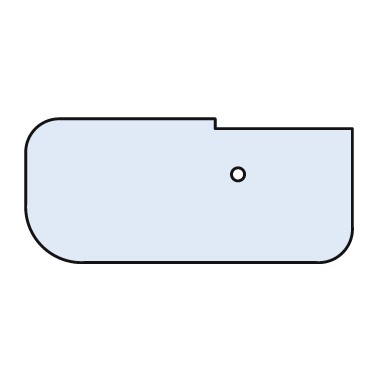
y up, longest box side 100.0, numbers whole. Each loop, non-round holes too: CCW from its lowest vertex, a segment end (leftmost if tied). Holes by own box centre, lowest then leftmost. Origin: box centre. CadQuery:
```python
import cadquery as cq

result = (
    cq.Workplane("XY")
    .moveTo(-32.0, -22.0)
    .lineTo(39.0, -22.0)
    .threePointArc((47.0, -19.0), (50.0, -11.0))
    .lineTo(50.0, 19.0)
    .lineTo(8.0, 19.0)
    .lineTo(8.0, 22.0)
    .lineTo(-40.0, 22.0)
    .threePointArc((-47.0, 19.0), (-50.0, 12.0))
    .lineTo(-50.0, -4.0)
    .threePointArc((-45.0, -17.0), (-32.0, -22.0))
    .close()
    .moveTo(15.0, 5.0)
    .circle(2.0)
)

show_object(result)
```